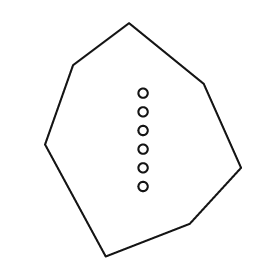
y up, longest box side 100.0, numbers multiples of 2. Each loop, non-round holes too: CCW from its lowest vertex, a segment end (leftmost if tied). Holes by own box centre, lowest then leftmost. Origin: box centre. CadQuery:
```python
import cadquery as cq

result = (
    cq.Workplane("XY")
    .moveTo(-16.0, -50.0)
    .lineTo(20.0, -36.0)
    .lineTo(42.0, -12.0)
    .lineTo(26.0, 24.0)
    .lineTo(-6.0, 50.0)
    .lineTo(-30.0, 32.0)
    .lineTo(-42.0, -2.0)
    .close()
    .moveTo(0.0, -20.0)
    .circle(2.0)
    .moveTo(0.0, -12.0)
    .circle(2.0)
    .moveTo(0.0, -4.0)
    .circle(2.0)
    .moveTo(0.0, 4.0)
    .circle(2.0)
    .moveTo(0.0, 12.0)
    .circle(2.0)
    .moveTo(0.0, 20.0)
    .circle(2.0)
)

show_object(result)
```